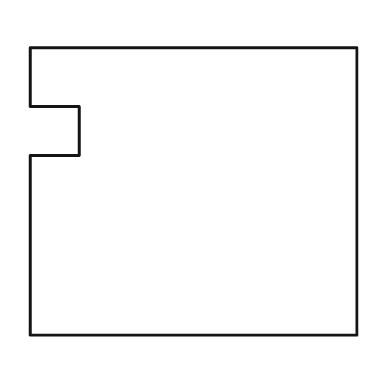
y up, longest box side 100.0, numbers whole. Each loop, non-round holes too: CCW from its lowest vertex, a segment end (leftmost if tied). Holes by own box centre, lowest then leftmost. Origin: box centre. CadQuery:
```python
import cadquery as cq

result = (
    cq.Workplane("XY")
    .moveTo(-50.0, -44.0)
    .lineTo(50.0, -44.0)
    .lineTo(50.0, 44.0)
    .lineTo(-50.0, 44.0)
    .lineTo(-50.0, 26.0)
    .lineTo(-35.0, 26.0)
    .lineTo(-35.0, 11.0)
    .lineTo(-50.0, 11.0)
    .close()
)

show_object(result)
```